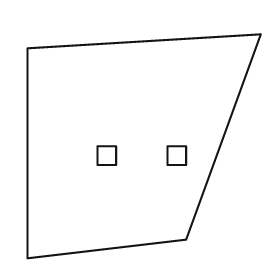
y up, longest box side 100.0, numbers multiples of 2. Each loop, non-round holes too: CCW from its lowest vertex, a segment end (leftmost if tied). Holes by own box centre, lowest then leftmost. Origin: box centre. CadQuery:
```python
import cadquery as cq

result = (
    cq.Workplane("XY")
    .moveTo(-50.0, -48.0)
    .lineTo(18.0, -40.0)
    .lineTo(50.0, 48.0)
    .lineTo(-50.0, 42.0)
    .close()
    .moveTo(-20.0, -8.0)
    .lineTo(-12.0, -8.0)
    .lineTo(-12.0, 0.0)
    .lineTo(-20.0, 0.0)
    .close()
    .moveTo(10.0, -8.0)
    .lineTo(18.0, -8.0)
    .lineTo(18.0, 0.0)
    .lineTo(10.0, 0.0)
    .close()
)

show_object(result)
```